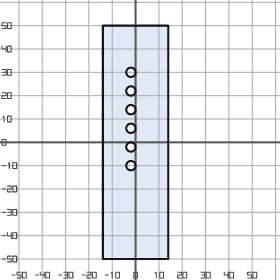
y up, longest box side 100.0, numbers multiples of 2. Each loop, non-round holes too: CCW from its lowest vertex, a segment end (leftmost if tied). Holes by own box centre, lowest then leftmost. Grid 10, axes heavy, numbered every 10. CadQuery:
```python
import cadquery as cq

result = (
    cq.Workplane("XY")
    .moveTo(-14.0, -50.0)
    .lineTo(14.0, -50.0)
    .lineTo(14.0, 50.0)
    .lineTo(-14.0, 50.0)
    .close()
    .moveTo(-2.0, -10.0)
    .circle(2.0)
    .moveTo(-2.0, -2.0)
    .circle(2.0)
    .moveTo(-2.0, 6.0)
    .circle(2.0)
    .moveTo(-2.0, 14.0)
    .circle(2.0)
    .moveTo(-2.0, 22.0)
    .circle(2.0)
    .moveTo(-2.0, 30.0)
    .circle(2.0)
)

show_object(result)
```